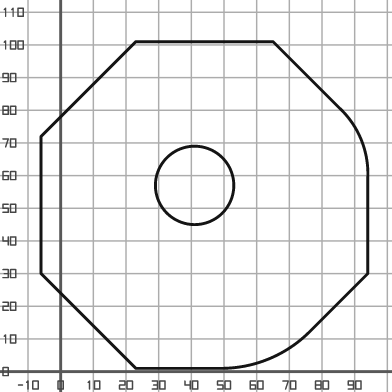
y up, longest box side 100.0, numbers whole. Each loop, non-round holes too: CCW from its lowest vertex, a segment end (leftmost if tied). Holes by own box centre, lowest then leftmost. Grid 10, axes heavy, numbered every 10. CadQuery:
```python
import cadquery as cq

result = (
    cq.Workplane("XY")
    .moveTo(23.0, 1.0)
    .lineTo(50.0, 1.0)
    .threePointArc((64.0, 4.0), (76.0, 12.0))
    .lineTo(94.0, 30.0)
    .lineTo(94.0, 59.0)
    .threePointArc((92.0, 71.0), (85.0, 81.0))
    .lineTo(65.0, 101.0)
    .lineTo(23.0, 101.0)
    .lineTo(-6.0, 72.0)
    .lineTo(-6.0, 30.0)
    .close()
    .moveTo(41.0, 57.0)
    .circle(12.0)
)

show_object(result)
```